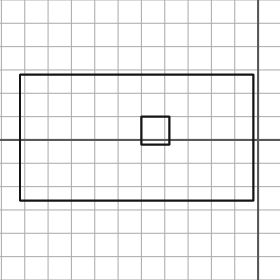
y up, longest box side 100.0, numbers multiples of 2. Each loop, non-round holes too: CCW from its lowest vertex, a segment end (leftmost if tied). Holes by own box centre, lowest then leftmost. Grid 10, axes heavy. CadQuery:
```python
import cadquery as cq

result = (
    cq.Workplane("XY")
    .moveTo(-102.0, -26.0)
    .lineTo(-2.0, -26.0)
    .lineTo(-2.0, 28.0)
    .lineTo(-102.0, 28.0)
    .close()
    .moveTo(-50.0, -2.0)
    .lineTo(-38.0, -2.0)
    .lineTo(-38.0, 10.0)
    .lineTo(-50.0, 10.0)
    .close()
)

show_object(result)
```